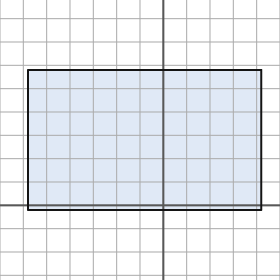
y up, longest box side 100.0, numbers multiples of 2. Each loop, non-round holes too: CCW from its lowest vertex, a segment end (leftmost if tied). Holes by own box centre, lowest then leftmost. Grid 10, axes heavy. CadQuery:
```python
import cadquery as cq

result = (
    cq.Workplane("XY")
    .moveTo(-58.0, -2.0)
    .lineTo(42.0, -2.0)
    .lineTo(42.0, 58.0)
    .lineTo(-58.0, 58.0)
    .close()
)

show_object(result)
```